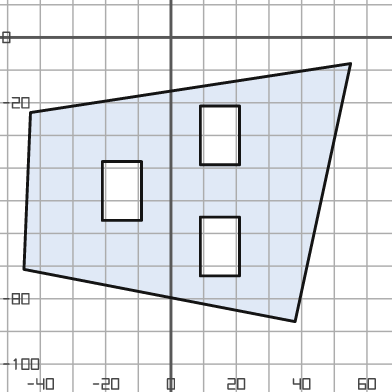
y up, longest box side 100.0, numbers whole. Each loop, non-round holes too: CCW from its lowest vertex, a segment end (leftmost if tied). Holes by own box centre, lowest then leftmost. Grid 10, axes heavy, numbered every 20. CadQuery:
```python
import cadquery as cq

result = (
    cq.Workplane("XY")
    .moveTo(38.0, -87.0)
    .lineTo(55.0, -8.0)
    .lineTo(-43.0, -23.0)
    .lineTo(-45.0, -71.0)
    .close()
    .moveTo(9.0, -73.0)
    .lineTo(21.0, -73.0)
    .lineTo(21.0, -55.0)
    .lineTo(9.0, -55.0)
    .close()
    .moveTo(-21.0, -56.0)
    .lineTo(-9.0, -56.0)
    .lineTo(-9.0, -38.0)
    .lineTo(-21.0, -38.0)
    .close()
    .moveTo(9.0, -39.0)
    .lineTo(21.0, -39.0)
    .lineTo(21.0, -21.0)
    .lineTo(9.0, -21.0)
    .close()
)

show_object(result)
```